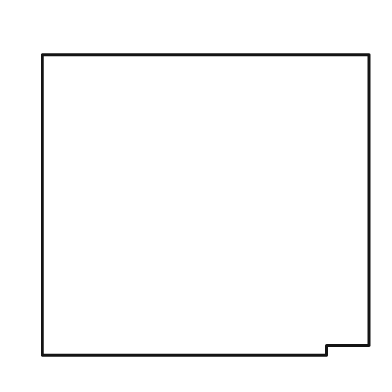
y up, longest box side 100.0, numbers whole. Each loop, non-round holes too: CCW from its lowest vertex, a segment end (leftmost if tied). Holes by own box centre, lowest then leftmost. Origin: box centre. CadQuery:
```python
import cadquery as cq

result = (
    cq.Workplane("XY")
    .moveTo(-50.0, -46.0)
    .lineTo(37.0, -46.0)
    .lineTo(37.0, -43.0)
    .lineTo(50.0, -43.0)
    .lineTo(50.0, 46.0)
    .lineTo(-50.0, 46.0)
    .close()
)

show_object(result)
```